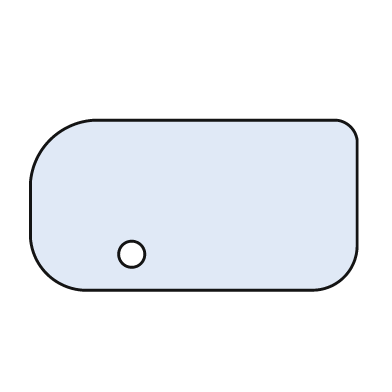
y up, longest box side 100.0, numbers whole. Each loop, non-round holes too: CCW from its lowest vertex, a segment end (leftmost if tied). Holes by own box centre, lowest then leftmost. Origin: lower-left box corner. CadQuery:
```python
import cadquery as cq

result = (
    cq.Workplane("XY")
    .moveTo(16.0, 0.0)
    .lineTo(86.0, 0.0)
    .threePointArc((96.0, 4.0), (100.0, 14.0))
    .lineTo(100.0, 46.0)
    .threePointArc((98.0, 50.0), (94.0, 52.0))
    .lineTo(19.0, 52.0)
    .threePointArc((6.0, 46.0), (0.0, 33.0))
    .lineTo(0.0, 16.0)
    .threePointArc((5.0, 5.0), (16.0, 0.0))
    .close()
    .moveTo(31.0, 11.0)
    .circle(4.0)
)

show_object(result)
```